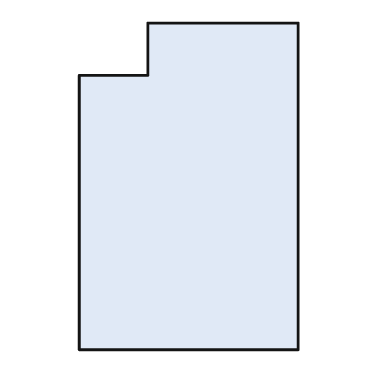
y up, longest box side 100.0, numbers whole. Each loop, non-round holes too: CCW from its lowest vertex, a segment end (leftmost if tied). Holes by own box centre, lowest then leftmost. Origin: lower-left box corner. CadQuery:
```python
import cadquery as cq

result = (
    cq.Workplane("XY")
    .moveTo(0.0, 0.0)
    .lineTo(67.0, 0.0)
    .lineTo(67.0, 100.0)
    .lineTo(21.0, 100.0)
    .lineTo(21.0, 84.0)
    .lineTo(0.0, 84.0)
    .close()
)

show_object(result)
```